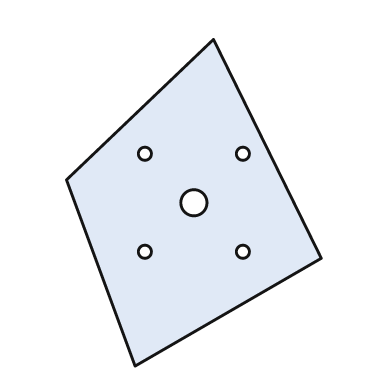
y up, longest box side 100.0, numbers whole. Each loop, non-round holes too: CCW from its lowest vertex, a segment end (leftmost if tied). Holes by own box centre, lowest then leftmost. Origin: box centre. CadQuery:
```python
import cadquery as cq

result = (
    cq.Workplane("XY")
    .moveTo(-18.0, -50.0)
    .lineTo(39.0, -17.0)
    .lineTo(6.0, 50.0)
    .lineTo(-39.0, 7.0)
    .close()
    .moveTo(-15.0, -15.0)
    .circle(2.0)
    .moveTo(15.0, -15.0)
    .circle(2.0)
    .moveTo(0.0, 0.0)
    .circle(4.0)
    .moveTo(-15.0, 15.0)
    .circle(2.0)
    .moveTo(15.0, 15.0)
    .circle(2.0)
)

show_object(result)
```